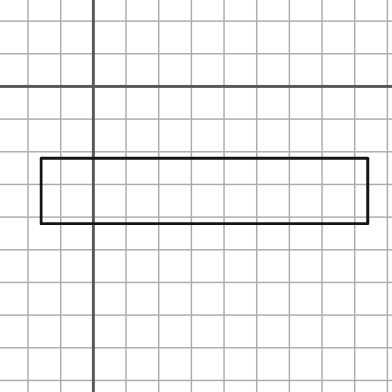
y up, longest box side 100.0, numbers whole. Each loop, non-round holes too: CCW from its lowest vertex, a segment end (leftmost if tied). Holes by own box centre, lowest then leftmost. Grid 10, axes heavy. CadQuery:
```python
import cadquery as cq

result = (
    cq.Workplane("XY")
    .moveTo(-16.0, -42.0)
    .lineTo(84.0, -42.0)
    .lineTo(84.0, -22.0)
    .lineTo(-16.0, -22.0)
    .close()
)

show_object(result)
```